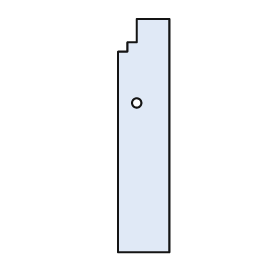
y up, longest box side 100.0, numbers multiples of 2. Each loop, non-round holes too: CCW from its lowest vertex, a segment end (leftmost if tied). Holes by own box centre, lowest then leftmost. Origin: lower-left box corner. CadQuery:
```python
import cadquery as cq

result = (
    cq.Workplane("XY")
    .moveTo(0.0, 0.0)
    .lineTo(22.0, 0.0)
    .lineTo(22.0, 100.0)
    .lineTo(8.0, 100.0)
    .lineTo(8.0, 90.0)
    .lineTo(4.0, 90.0)
    .lineTo(4.0, 86.0)
    .lineTo(0.0, 86.0)
    .close()
    .moveTo(8.0, 64.0)
    .circle(2.0)
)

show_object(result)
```